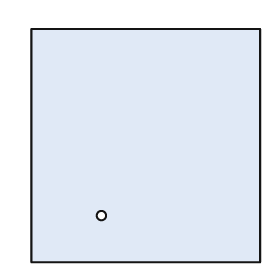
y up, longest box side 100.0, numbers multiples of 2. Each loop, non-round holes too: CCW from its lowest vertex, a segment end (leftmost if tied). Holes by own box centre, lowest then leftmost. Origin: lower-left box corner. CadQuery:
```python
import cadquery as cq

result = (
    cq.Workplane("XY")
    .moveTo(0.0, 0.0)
    .lineTo(98.0, 0.0)
    .lineTo(98.0, 100.0)
    .lineTo(0.0, 100.0)
    .close()
    .moveTo(30.0, 20.0)
    .circle(2.0)
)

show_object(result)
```